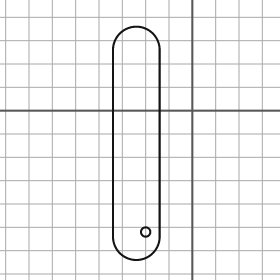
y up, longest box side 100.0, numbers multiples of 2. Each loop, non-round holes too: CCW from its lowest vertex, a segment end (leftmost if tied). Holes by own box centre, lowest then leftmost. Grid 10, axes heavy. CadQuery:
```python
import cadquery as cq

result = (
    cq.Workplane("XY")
    .moveTo(-34.0, -54.0)
    .threePointArc((-24.0, -64.0), (-14.0, -54.0))
    .lineTo(-14.0, 26.0)
    .threePointArc((-24.0, 36.0), (-34.0, 26.0))
    .close()
    .moveTo(-20.0, -52.0)
    .circle(2.0)
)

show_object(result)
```